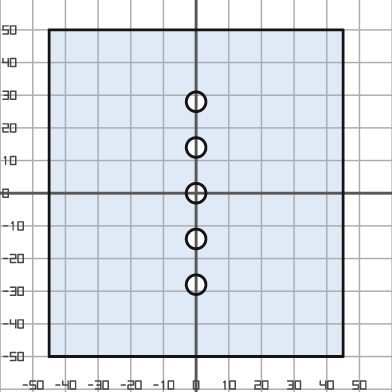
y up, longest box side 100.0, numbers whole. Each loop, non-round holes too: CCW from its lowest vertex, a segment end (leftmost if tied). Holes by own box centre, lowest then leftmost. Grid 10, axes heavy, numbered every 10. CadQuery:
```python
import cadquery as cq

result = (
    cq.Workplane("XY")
    .moveTo(-45.0, -50.0)
    .lineTo(45.0, -50.0)
    .lineTo(45.0, 50.0)
    .lineTo(-45.0, 50.0)
    .close()
    .moveTo(0.0, -28.0)
    .circle(3.0)
    .moveTo(0.0, -14.0)
    .circle(3.0)
    .moveTo(0.0, 0.0)
    .circle(3.0)
    .moveTo(0.0, 14.0)
    .circle(3.0)
    .moveTo(0.0, 28.0)
    .circle(3.0)
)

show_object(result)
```